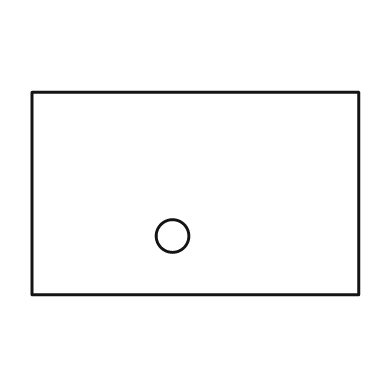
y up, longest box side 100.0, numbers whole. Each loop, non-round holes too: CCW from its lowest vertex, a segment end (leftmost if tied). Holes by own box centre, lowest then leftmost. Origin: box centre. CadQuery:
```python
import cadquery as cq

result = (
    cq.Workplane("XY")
    .moveTo(-50.0, -31.0)
    .lineTo(50.0, -31.0)
    .lineTo(50.0, 31.0)
    .lineTo(-50.0, 31.0)
    .close()
    .moveTo(-7.0, -13.0)
    .circle(5.0)
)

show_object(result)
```